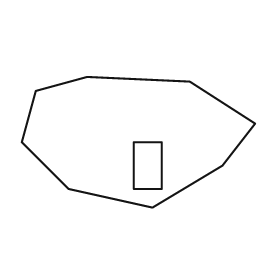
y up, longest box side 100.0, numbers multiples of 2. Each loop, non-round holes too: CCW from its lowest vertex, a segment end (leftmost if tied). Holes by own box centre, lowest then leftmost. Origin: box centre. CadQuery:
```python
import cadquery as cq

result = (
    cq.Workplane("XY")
    .moveTo(6.0, -28.0)
    .lineTo(36.0, -10.0)
    .lineTo(50.0, 8.0)
    .lineTo(22.0, 26.0)
    .lineTo(-22.0, 28.0)
    .lineTo(-44.0, 22.0)
    .lineTo(-50.0, 0.0)
    .lineTo(-30.0, -20.0)
    .close()
    .moveTo(-2.0, -20.0)
    .lineTo(10.0, -20.0)
    .lineTo(10.0, 0.0)
    .lineTo(-2.0, 0.0)
    .close()
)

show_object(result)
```